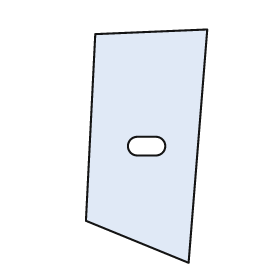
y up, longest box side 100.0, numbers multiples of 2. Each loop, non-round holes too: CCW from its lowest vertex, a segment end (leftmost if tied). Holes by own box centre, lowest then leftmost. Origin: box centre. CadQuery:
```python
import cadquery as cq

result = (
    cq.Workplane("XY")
    .moveTo(18.0, -50.0)
    .lineTo(26.0, 50.0)
    .lineTo(-22.0, 48.0)
    .lineTo(-26.0, -32.0)
    .close()
    .moveTo(-4.0, -4.0)
    .lineTo(4.0, -4.0)
    .threePointArc((8.0, 0.0), (4.0, 4.0))
    .lineTo(-4.0, 4.0)
    .threePointArc((-8.0, 0.0), (-4.0, -4.0))
    .close()
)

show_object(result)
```